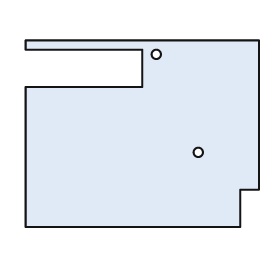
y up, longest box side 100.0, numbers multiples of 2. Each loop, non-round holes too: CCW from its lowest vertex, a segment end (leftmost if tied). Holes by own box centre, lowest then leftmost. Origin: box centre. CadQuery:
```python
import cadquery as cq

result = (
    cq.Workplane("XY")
    .moveTo(-50.0, -40.0)
    .lineTo(42.0, -40.0)
    .lineTo(42.0, -24.0)
    .lineTo(50.0, -24.0)
    .lineTo(50.0, 40.0)
    .lineTo(-50.0, 40.0)
    .lineTo(-50.0, 36.0)
    .lineTo(0.0, 36.0)
    .lineTo(0.0, 20.0)
    .lineTo(-50.0, 20.0)
    .close()
    .moveTo(24.0, -8.0)
    .circle(2.0)
    .moveTo(6.0, 34.0)
    .circle(2.0)
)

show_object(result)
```